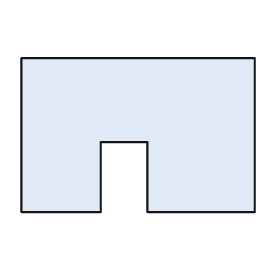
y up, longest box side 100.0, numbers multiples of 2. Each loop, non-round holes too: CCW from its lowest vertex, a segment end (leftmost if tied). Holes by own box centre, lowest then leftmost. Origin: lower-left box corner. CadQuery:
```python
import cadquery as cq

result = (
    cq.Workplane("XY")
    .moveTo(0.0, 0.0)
    .lineTo(34.0, 0.0)
    .lineTo(34.0, 30.0)
    .lineTo(54.0, 30.0)
    .lineTo(54.0, 0.0)
    .lineTo(100.0, 0.0)
    .lineTo(100.0, 66.0)
    .lineTo(0.0, 66.0)
    .close()
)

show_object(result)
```